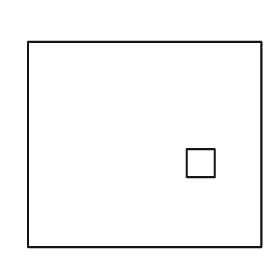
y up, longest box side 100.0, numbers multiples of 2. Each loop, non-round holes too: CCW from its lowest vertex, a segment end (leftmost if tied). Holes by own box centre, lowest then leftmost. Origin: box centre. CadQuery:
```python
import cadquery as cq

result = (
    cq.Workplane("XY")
    .moveTo(-50.0, -44.0)
    .lineTo(50.0, -44.0)
    .lineTo(50.0, 44.0)
    .lineTo(-50.0, 44.0)
    .close()
    .moveTo(18.0, -14.0)
    .lineTo(30.0, -14.0)
    .lineTo(30.0, -2.0)
    .lineTo(18.0, -2.0)
    .close()
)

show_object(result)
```